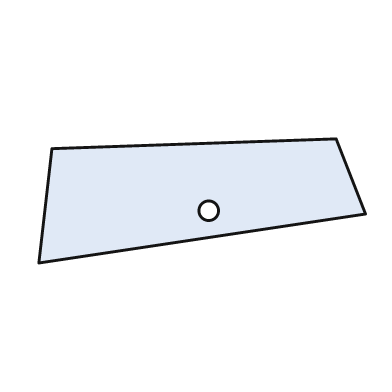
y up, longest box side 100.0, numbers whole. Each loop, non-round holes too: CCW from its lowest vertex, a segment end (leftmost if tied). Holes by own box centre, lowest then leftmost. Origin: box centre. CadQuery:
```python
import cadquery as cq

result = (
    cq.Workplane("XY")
    .moveTo(-50.0, -19.0)
    .lineTo(50.0, -4.0)
    .lineTo(41.0, 19.0)
    .lineTo(-46.0, 16.0)
    .close()
    .moveTo(2.0, -3.0)
    .circle(3.0)
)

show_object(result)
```